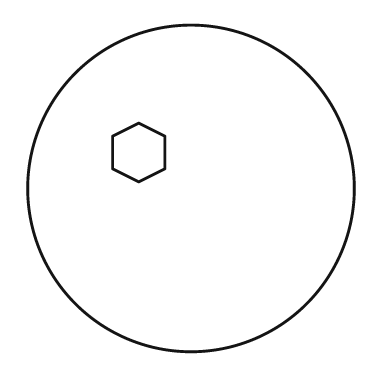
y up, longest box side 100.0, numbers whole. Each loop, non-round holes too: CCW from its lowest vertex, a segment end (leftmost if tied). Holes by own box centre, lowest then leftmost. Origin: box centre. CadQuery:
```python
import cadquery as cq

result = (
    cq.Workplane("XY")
    .moveTo(0.0, 0.0)
    .circle(50.0)
    .moveTo(-16.0, 2.0)
    .lineTo(-8.0, 6.0)
    .lineTo(-8.0, 16.0)
    .lineTo(-16.0, 20.0)
    .lineTo(-24.0, 16.0)
    .lineTo(-24.0, 6.0)
    .close()
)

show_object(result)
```